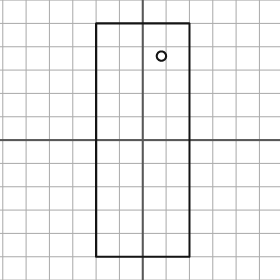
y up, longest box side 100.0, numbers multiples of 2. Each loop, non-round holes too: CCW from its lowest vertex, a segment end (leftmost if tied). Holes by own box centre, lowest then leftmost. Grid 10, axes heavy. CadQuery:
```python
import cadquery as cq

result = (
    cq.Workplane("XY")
    .moveTo(-20.0, -50.0)
    .lineTo(20.0, -50.0)
    .lineTo(20.0, 50.0)
    .lineTo(-20.0, 50.0)
    .close()
    .moveTo(8.0, 36.0)
    .circle(2.0)
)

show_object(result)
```